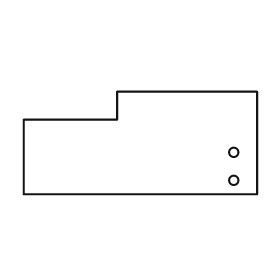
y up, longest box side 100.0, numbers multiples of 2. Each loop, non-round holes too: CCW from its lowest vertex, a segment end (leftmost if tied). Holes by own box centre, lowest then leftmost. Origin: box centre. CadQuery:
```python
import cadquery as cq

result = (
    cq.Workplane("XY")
    .moveTo(-50.0, -22.0)
    .lineTo(50.0, -22.0)
    .lineTo(50.0, 22.0)
    .lineTo(-10.0, 22.0)
    .lineTo(-10.0, 10.0)
    .lineTo(-50.0, 10.0)
    .close()
    .moveTo(40.0, -16.0)
    .circle(2.0)
    .moveTo(40.0, -4.0)
    .circle(2.0)
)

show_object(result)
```